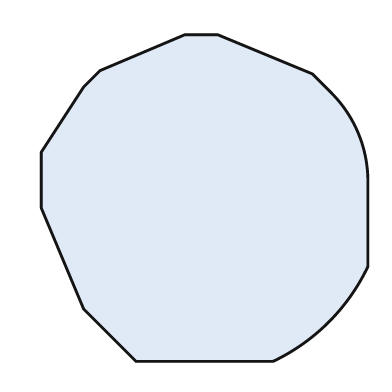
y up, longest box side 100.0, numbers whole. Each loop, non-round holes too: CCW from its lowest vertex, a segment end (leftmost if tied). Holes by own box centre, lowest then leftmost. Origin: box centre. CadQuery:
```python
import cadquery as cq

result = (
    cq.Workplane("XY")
    .moveTo(-21.0, -50.0)
    .lineTo(21.0, -50.0)
    .threePointArc((38.0, -38.0), (50.0, -21.0))
    .lineTo(50.0, 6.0)
    .threePointArc((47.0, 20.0), (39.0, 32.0))
    .lineTo(33.0, 38.0)
    .lineTo(4.0, 50.0)
    .lineTo(-6.0, 50.0)
    .lineTo(-32.0, 39.0)
    .lineTo(-37.0, 34.0)
    .lineTo(-50.0, 14.0)
    .lineTo(-50.0, -3.0)
    .lineTo(-37.0, -34.0)
    .close()
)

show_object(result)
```